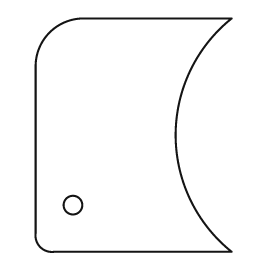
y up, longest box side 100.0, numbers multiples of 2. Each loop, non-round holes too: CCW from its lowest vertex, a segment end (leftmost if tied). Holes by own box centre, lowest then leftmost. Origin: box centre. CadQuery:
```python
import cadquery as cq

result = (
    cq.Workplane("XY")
    .moveTo(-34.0, -50.0)
    .lineTo(42.0, -50.0)
    .threePointArc((18.0, 0.0), (42.0, 50.0))
    .lineTo(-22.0, 50.0)
    .threePointArc((-36.0, 44.0), (-42.0, 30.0))
    .lineTo(-42.0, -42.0)
    .threePointArc((-40.0, -48.0), (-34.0, -50.0))
    .close()
    .moveTo(-26.0, -30.0)
    .circle(4.0)
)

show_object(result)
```